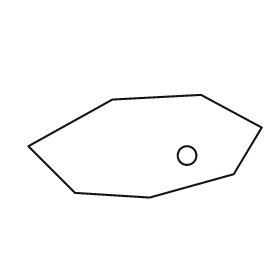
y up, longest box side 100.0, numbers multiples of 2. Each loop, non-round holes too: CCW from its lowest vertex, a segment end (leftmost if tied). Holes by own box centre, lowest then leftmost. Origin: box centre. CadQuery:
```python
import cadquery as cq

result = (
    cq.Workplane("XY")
    .moveTo(2.0, -22.0)
    .lineTo(38.0, -12.0)
    .lineTo(50.0, 8.0)
    .lineTo(24.0, 22.0)
    .lineTo(-14.0, 20.0)
    .lineTo(-50.0, 0.0)
    .lineTo(-30.0, -20.0)
    .close()
    .moveTo(18.0, -4.0)
    .circle(4.0)
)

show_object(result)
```